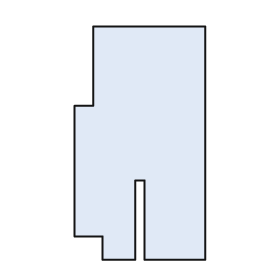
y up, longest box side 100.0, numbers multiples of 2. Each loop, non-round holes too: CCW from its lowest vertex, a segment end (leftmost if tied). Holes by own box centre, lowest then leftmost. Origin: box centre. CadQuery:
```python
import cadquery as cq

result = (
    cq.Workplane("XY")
    .moveTo(-16.0, -50.0)
    .lineTo(-2.0, -50.0)
    .lineTo(-2.0, -16.0)
    .lineTo(2.0, -16.0)
    .lineTo(2.0, -50.0)
    .lineTo(28.0, -50.0)
    .lineTo(28.0, 50.0)
    .lineTo(-20.0, 50.0)
    .lineTo(-20.0, 16.0)
    .lineTo(-28.0, 16.0)
    .lineTo(-28.0, -40.0)
    .lineTo(-16.0, -40.0)
    .close()
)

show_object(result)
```